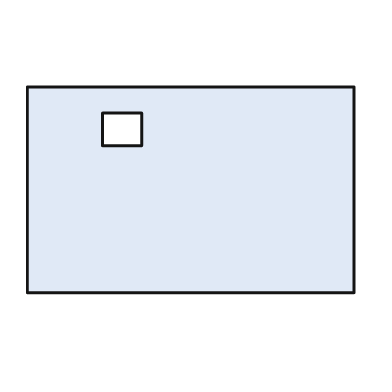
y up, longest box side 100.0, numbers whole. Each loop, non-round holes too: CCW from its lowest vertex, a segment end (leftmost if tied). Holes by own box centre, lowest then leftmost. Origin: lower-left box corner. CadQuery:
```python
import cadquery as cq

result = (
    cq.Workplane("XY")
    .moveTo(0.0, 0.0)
    .lineTo(100.0, 0.0)
    .lineTo(100.0, 63.0)
    .lineTo(0.0, 63.0)
    .close()
    .moveTo(23.0, 45.0)
    .lineTo(35.0, 45.0)
    .lineTo(35.0, 55.0)
    .lineTo(23.0, 55.0)
    .close()
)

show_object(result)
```